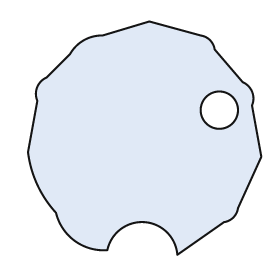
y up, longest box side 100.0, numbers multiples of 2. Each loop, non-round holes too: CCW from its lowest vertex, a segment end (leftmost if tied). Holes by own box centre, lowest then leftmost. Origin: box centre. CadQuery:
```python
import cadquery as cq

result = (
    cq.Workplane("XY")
    .moveTo(14.0, -50.0)
    .lineTo(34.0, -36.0)
    .threePointArc((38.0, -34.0), (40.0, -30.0))
    .lineTo(50.0, -8.0)
    .lineTo(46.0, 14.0)
    .threePointArc((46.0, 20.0), (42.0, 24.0))
    .lineTo(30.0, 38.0)
    .threePointArc((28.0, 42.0), (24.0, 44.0))
    .lineTo(2.0, 50.0)
    .lineTo(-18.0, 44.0)
    .threePointArc((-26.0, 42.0), (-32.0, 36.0))
    .lineTo(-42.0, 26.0)
    .threePointArc((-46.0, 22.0), (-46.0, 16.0))
    .lineTo(-50.0, -6.0)
    .threePointArc((-46.0, -20.0), (-38.0, -32.0))
    .threePointArc((-30.0, -44.0), (-16.0, -48.0))
    .threePointArc((0.0, -36.0), (14.0, -50.0))
    .close()
    .moveTo(32.0, 12.0)
    .circle(8.0)
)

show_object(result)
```